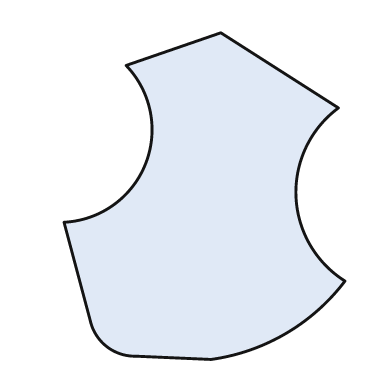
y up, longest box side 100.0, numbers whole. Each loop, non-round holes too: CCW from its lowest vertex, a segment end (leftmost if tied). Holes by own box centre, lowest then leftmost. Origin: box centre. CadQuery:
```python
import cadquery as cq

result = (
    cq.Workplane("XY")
    .moveTo(2.0, -50.0)
    .threePointArc((25.0, -42.0), (43.0, -26.0))
    .threePointArc((28.0, 0.0), (41.0, 27.0))
    .lineTo(5.0, 50.0)
    .lineTo(-24.0, 40.0)
    .threePointArc((-18.0, 10.0), (-43.0, -8.0))
    .lineTo(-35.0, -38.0)
    .threePointArc((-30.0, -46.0), (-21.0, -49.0))
    .close()
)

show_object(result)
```